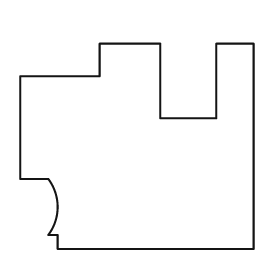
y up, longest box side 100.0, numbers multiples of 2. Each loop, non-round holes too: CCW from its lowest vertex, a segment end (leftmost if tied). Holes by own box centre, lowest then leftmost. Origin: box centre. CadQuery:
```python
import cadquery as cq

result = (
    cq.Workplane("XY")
    .moveTo(-34.0, -44.0)
    .lineTo(50.0, -44.0)
    .lineTo(50.0, 44.0)
    .lineTo(34.0, 44.0)
    .lineTo(34.0, 12.0)
    .lineTo(10.0, 12.0)
    .lineTo(10.0, 44.0)
    .lineTo(-16.0, 44.0)
    .lineTo(-16.0, 30.0)
    .lineTo(-50.0, 30.0)
    .lineTo(-50.0, -14.0)
    .lineTo(-38.0, -14.0)
    .threePointArc((-34.0, -26.0), (-38.0, -38.0))
    .lineTo(-34.0, -38.0)
    .close()
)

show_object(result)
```